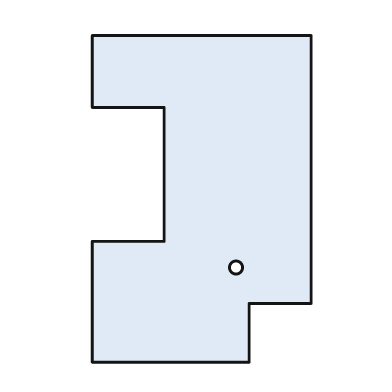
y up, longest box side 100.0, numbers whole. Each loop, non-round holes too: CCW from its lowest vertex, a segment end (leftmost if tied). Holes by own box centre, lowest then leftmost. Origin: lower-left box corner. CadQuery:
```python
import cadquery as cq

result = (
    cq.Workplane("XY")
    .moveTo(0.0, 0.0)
    .lineTo(48.0, 0.0)
    .lineTo(48.0, 18.0)
    .lineTo(67.0, 18.0)
    .lineTo(67.0, 100.0)
    .lineTo(0.0, 100.0)
    .lineTo(0.0, 78.0)
    .lineTo(22.0, 78.0)
    .lineTo(22.0, 37.0)
    .lineTo(0.0, 37.0)
    .close()
    .moveTo(44.0, 29.0)
    .circle(2.0)
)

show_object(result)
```